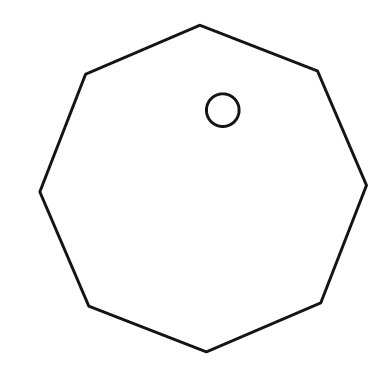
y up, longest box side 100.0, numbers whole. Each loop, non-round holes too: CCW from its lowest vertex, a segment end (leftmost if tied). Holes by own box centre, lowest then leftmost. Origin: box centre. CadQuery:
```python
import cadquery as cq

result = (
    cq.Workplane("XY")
    .moveTo(1.0, -50.0)
    .lineTo(36.0, -35.0)
    .lineTo(50.0, 1.0)
    .lineTo(35.0, 36.0)
    .lineTo(-1.0, 50.0)
    .lineTo(-36.0, 35.0)
    .lineTo(-50.0, -1.0)
    .lineTo(-35.0, -36.0)
    .close()
    .moveTo(6.0, 24.0)
    .circle(5.0)
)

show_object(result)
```